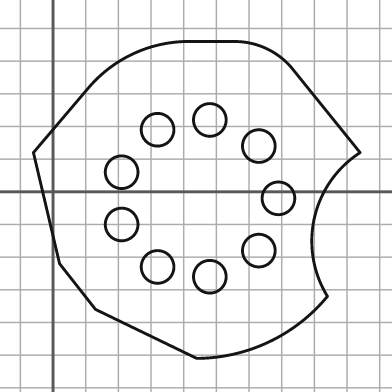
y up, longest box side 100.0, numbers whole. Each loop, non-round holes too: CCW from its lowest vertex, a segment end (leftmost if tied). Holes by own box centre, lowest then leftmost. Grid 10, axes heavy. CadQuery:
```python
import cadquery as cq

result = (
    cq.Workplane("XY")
    .moveTo(44.0, -51.0)
    .threePointArc((66.0, -46.0), (84.0, -32.0))
    .threePointArc((80.0, -8.0), (94.0, 12.0))
    .lineTo(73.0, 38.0)
    .threePointArc((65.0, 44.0), (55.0, 46.0))
    .lineTo(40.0, 46.0)
    .threePointArc((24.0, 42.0), (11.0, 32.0))
    .lineTo(-6.0, 12.0)
    .lineTo(2.0, -22.0)
    .lineTo(13.0, -36.0)
    .close()
    .moveTo(48.0, -26.0)
    .circle(5.0)
    .moveTo(32.0, -23.0)
    .circle(5.0)
    .moveTo(63.0, -18.0)
    .circle(5.0)
    .moveTo(21.0, -10.0)
    .circle(5.0)
    .moveTo(69.0, -2.0)
    .circle(5.0)
    .moveTo(21.0, 6.0)
    .circle(5.0)
    .moveTo(63.0, 14.0)
    .circle(5.0)
    .moveTo(32.0, 19.0)
    .circle(5.0)
    .moveTo(48.0, 22.0)
    .circle(5.0)
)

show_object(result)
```